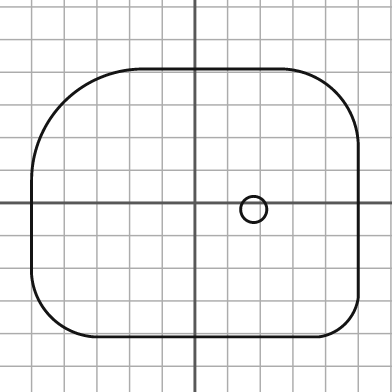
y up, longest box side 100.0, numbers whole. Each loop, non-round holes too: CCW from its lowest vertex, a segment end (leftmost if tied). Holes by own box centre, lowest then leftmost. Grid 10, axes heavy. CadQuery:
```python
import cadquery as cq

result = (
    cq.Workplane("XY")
    .moveTo(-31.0, -41.0)
    .lineTo(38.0, -41.0)
    .threePointArc((46.0, -37.0), (50.0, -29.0))
    .lineTo(50.0, 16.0)
    .threePointArc((43.0, 34.0), (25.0, 41.0))
    .lineTo(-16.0, 41.0)
    .threePointArc((-40.0, 31.0), (-50.0, 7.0))
    .lineTo(-50.0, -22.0)
    .threePointArc((-44.0, -35.0), (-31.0, -41.0))
    .close()
    .moveTo(18.0, -2.0)
    .circle(4.0)
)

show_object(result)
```